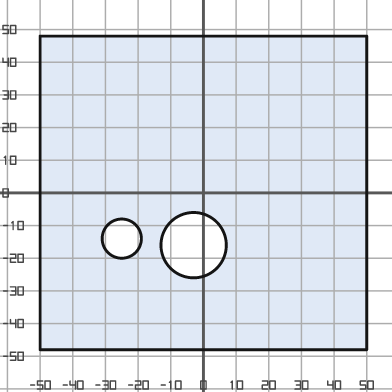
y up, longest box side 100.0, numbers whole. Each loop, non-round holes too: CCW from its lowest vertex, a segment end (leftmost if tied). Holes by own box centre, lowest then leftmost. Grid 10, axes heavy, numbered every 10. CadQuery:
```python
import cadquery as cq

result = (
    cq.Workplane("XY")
    .moveTo(-50.0, -48.0)
    .lineTo(50.0, -48.0)
    .lineTo(50.0, 48.0)
    .lineTo(-50.0, 48.0)
    .close()
    .moveTo(-3.0, -16.0)
    .circle(10.0)
    .moveTo(-25.0, -14.0)
    .circle(6.0)
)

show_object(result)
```